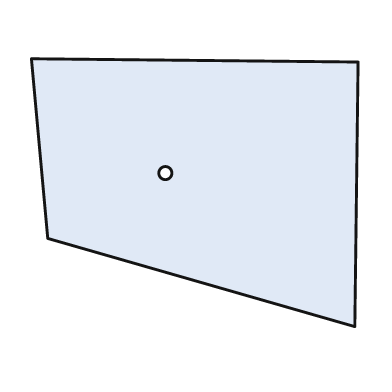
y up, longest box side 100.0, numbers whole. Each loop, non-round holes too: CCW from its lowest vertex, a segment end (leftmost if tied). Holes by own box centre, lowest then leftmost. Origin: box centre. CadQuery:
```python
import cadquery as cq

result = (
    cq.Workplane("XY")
    .moveTo(49.0, -41.0)
    .lineTo(50.0, 40.0)
    .lineTo(-50.0, 41.0)
    .lineTo(-45.0, -14.0)
    .close()
    .moveTo(-9.0, 6.0)
    .circle(2.0)
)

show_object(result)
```